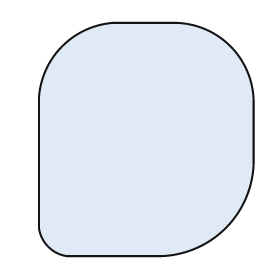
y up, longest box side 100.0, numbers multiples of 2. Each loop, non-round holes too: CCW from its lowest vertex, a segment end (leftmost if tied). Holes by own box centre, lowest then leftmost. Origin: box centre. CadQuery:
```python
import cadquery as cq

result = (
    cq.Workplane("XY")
    .moveTo(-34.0, -50.0)
    .lineTo(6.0, -50.0)
    .threePointArc((34.0, -38.0), (46.0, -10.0))
    .lineTo(46.0, 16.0)
    .threePointArc((36.0, 40.0), (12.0, 50.0))
    .lineTo(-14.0, 50.0)
    .threePointArc((-36.0, 40.0), (-46.0, 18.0))
    .lineTo(-46.0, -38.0)
    .threePointArc((-42.0, -46.0), (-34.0, -50.0))
    .close()
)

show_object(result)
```